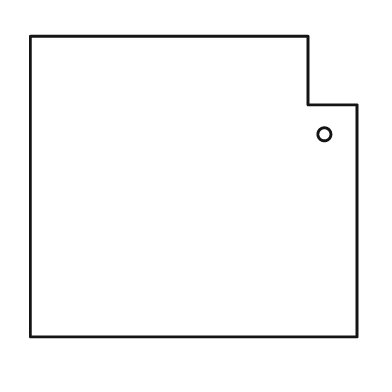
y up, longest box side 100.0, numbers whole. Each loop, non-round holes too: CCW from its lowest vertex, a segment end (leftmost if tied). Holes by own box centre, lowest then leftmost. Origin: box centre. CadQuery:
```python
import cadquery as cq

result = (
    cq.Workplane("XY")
    .moveTo(-50.0, -46.0)
    .lineTo(50.0, -46.0)
    .lineTo(50.0, 25.0)
    .lineTo(35.0, 25.0)
    .lineTo(35.0, 46.0)
    .lineTo(-50.0, 46.0)
    .close()
    .moveTo(40.0, 16.0)
    .circle(2.0)
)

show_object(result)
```